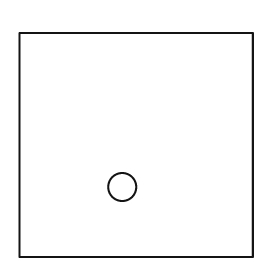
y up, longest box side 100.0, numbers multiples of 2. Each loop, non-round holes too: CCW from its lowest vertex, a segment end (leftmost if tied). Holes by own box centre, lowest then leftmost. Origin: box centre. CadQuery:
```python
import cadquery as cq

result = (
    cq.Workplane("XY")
    .moveTo(-50.0, -48.0)
    .lineTo(50.0, -48.0)
    .lineTo(50.0, 48.0)
    .lineTo(-50.0, 48.0)
    .close()
    .moveTo(-6.0, -18.0)
    .circle(6.0)
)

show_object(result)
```